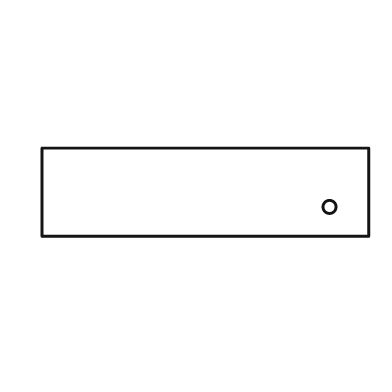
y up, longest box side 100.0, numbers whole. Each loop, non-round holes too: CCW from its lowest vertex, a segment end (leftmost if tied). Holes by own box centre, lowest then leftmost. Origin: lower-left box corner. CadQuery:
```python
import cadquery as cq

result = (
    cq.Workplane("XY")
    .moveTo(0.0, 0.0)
    .lineTo(100.0, 0.0)
    .lineTo(100.0, 27.0)
    .lineTo(0.0, 27.0)
    .close()
    .moveTo(88.0, 9.0)
    .circle(2.0)
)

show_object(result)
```